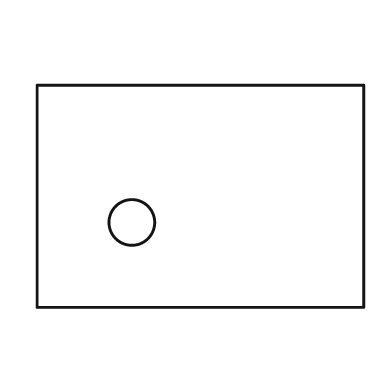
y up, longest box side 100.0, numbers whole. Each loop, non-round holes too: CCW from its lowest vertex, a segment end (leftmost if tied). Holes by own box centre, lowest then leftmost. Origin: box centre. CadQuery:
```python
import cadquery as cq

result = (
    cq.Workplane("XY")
    .moveTo(-50.0, -34.0)
    .lineTo(50.0, -34.0)
    .lineTo(50.0, 34.0)
    .lineTo(-50.0, 34.0)
    .close()
    .moveTo(-21.0, -8.0)
    .circle(7.0)
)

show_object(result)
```